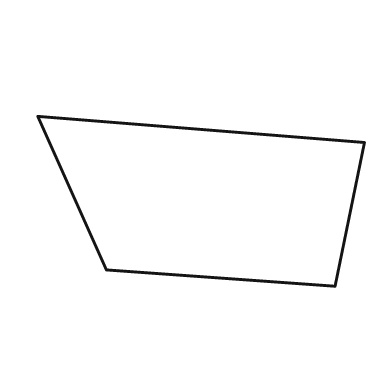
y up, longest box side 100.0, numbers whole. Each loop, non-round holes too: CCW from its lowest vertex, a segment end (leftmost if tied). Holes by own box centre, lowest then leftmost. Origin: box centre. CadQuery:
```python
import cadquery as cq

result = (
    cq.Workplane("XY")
    .moveTo(41.0, -26.0)
    .lineTo(50.0, 18.0)
    .lineTo(-50.0, 26.0)
    .lineTo(-29.0, -21.0)
    .close()
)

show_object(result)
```